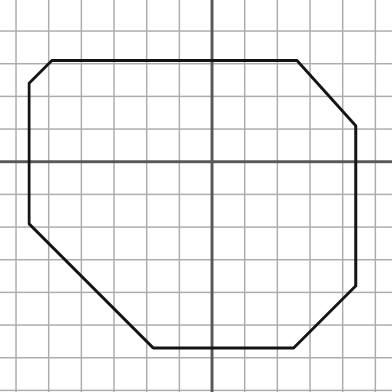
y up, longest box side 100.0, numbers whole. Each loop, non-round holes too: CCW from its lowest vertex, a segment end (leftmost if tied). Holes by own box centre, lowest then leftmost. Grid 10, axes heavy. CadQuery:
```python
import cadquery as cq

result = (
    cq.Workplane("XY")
    .moveTo(-18.0, -57.0)
    .lineTo(25.0, -57.0)
    .lineTo(44.0, -38.0)
    .lineTo(44.0, 11.0)
    .lineTo(26.0, 31.0)
    .lineTo(-49.0, 31.0)
    .lineTo(-56.0, 24.0)
    .lineTo(-56.0, -19.0)
    .close()
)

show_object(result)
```